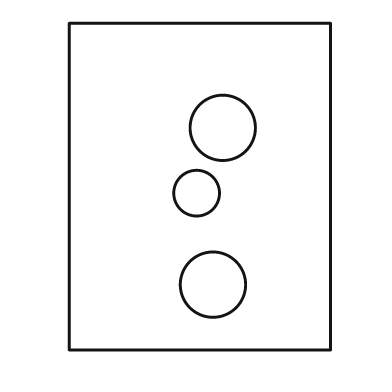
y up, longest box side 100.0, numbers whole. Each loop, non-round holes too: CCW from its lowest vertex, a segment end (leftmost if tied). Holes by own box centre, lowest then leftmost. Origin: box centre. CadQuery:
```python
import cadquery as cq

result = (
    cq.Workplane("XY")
    .moveTo(-40.0, -50.0)
    .lineTo(40.0, -50.0)
    .lineTo(40.0, 50.0)
    .lineTo(-40.0, 50.0)
    .close()
    .moveTo(4.0, -30.0)
    .circle(10.0)
    .moveTo(-1.0, -2.0)
    .circle(7.0)
    .moveTo(7.0, 18.0)
    .circle(10.0)
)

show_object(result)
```